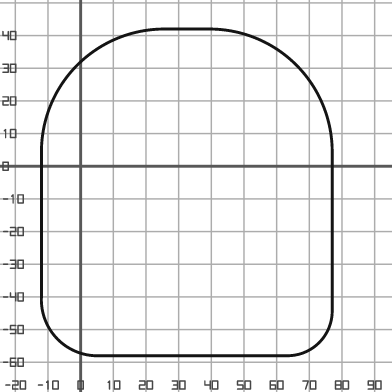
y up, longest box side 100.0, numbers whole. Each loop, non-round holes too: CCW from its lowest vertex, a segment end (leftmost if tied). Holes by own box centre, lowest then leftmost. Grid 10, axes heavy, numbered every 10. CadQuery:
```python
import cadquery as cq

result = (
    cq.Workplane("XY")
    .moveTo(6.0, -58.0)
    .lineTo(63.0, -58.0)
    .threePointArc((73.0, -54.0), (77.0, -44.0))
    .lineTo(77.0, 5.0)
    .threePointArc((66.0, 31.0), (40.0, 42.0))
    .lineTo(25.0, 42.0)
    .threePointArc((-1.0, 31.0), (-12.0, 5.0))
    .lineTo(-12.0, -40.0)
    .threePointArc((-7.0, -53.0), (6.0, -58.0))
    .close()
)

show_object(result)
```